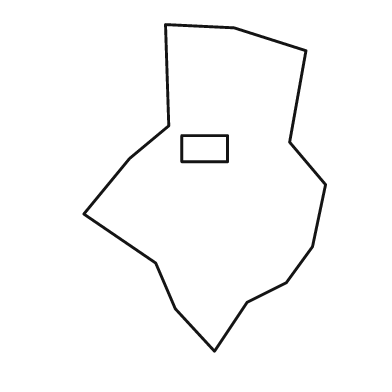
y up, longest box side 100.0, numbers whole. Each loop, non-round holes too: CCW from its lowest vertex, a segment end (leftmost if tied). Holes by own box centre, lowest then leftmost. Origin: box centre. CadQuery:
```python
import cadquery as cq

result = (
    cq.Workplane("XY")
    .moveTo(3.0, -50.0)
    .lineTo(13.0, -35.0)
    .lineTo(25.0, -29.0)
    .lineTo(33.0, -18.0)
    .lineTo(37.0, 1.0)
    .lineTo(26.0, 14.0)
    .lineTo(31.0, 42.0)
    .lineTo(9.0, 49.0)
    .lineTo(-12.0, 50.0)
    .lineTo(-11.0, 19.0)
    .lineTo(-23.0, 9.0)
    .lineTo(-37.0, -8.0)
    .lineTo(-15.0, -23.0)
    .lineTo(-9.0, -37.0)
    .close()
    .moveTo(-7.0, 8.0)
    .lineTo(7.0, 8.0)
    .lineTo(7.0, 16.0)
    .lineTo(-7.0, 16.0)
    .close()
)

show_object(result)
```